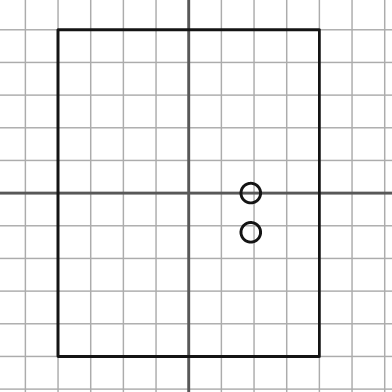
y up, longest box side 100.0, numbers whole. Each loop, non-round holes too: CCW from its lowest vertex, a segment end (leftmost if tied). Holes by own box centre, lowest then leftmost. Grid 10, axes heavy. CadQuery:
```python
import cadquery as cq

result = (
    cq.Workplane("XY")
    .moveTo(-40.0, -50.0)
    .lineTo(40.0, -50.0)
    .lineTo(40.0, 50.0)
    .lineTo(-40.0, 50.0)
    .close()
    .moveTo(19.0, -12.0)
    .circle(3.0)
    .moveTo(19.0, 0.0)
    .circle(3.0)
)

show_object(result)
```